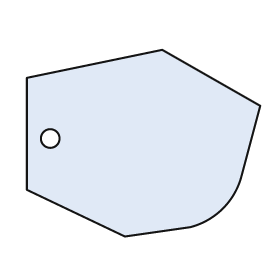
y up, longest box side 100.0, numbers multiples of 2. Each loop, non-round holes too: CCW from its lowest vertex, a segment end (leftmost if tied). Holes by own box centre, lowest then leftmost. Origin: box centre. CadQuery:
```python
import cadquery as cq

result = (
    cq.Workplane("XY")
    .moveTo(-8.0, -40.0)
    .lineTo(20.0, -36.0)
    .threePointArc((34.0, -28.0), (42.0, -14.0))
    .lineTo(50.0, 16.0)
    .lineTo(8.0, 40.0)
    .lineTo(-50.0, 28.0)
    .lineTo(-50.0, -20.0)
    .close()
    .moveTo(-40.0, 2.0)
    .circle(4.0)
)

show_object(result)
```